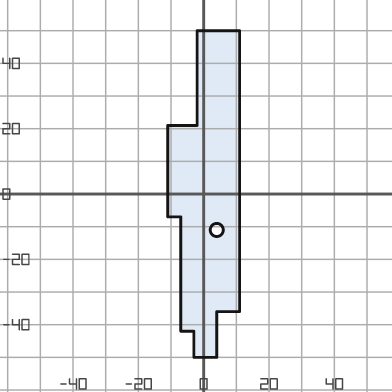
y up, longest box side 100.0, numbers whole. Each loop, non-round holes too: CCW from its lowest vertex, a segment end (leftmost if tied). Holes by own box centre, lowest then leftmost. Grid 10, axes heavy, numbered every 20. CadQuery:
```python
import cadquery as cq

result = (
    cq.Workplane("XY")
    .moveTo(-3.0, -50.0)
    .lineTo(4.0, -50.0)
    .lineTo(4.0, -36.0)
    .lineTo(11.0, -36.0)
    .lineTo(11.0, 50.0)
    .lineTo(-2.0, 50.0)
    .lineTo(-2.0, 21.0)
    .lineTo(-11.0, 21.0)
    .lineTo(-11.0, -7.0)
    .lineTo(-7.0, -7.0)
    .lineTo(-7.0, -42.0)
    .lineTo(-3.0, -42.0)
    .close()
    .moveTo(4.0, -11.0)
    .circle(2.0)
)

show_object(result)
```